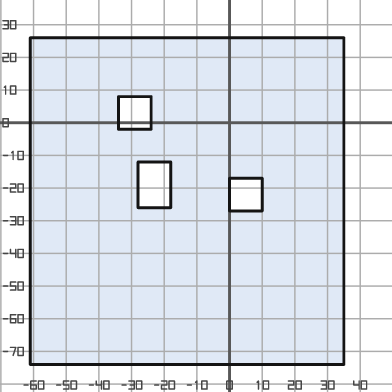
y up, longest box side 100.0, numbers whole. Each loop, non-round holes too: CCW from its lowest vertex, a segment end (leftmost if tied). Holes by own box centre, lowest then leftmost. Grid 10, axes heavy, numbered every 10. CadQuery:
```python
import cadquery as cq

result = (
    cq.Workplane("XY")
    .moveTo(-61.0, -74.0)
    .lineTo(35.0, -74.0)
    .lineTo(35.0, 26.0)
    .lineTo(-61.0, 26.0)
    .close()
    .moveTo(0.0, -27.0)
    .lineTo(10.0, -27.0)
    .lineTo(10.0, -17.0)
    .lineTo(0.0, -17.0)
    .close()
    .moveTo(-28.0, -26.0)
    .lineTo(-18.0, -26.0)
    .lineTo(-18.0, -12.0)
    .lineTo(-28.0, -12.0)
    .close()
    .moveTo(-34.0, -2.0)
    .lineTo(-24.0, -2.0)
    .lineTo(-24.0, 8.0)
    .lineTo(-34.0, 8.0)
    .close()
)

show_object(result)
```